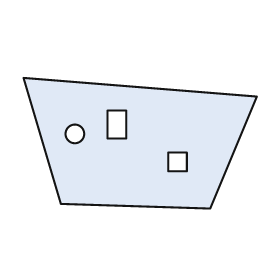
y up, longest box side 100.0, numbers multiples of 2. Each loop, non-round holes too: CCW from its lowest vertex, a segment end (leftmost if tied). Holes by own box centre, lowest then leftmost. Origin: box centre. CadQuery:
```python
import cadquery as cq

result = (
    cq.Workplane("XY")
    .moveTo(30.0, -28.0)
    .lineTo(50.0, 20.0)
    .lineTo(-50.0, 28.0)
    .lineTo(-34.0, -26.0)
    .close()
    .moveTo(12.0, -12.0)
    .lineTo(20.0, -12.0)
    .lineTo(20.0, -4.0)
    .lineTo(12.0, -4.0)
    .close()
    .moveTo(-28.0, 4.0)
    .circle(4.0)
    .moveTo(-14.0, 2.0)
    .lineTo(-6.0, 2.0)
    .lineTo(-6.0, 14.0)
    .lineTo(-14.0, 14.0)
    .close()
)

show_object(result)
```